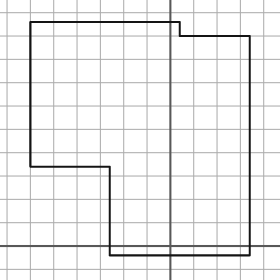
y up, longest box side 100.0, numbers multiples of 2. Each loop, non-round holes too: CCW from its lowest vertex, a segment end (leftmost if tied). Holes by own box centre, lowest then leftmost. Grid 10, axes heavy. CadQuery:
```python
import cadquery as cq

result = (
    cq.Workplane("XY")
    .moveTo(-26.0, -4.0)
    .lineTo(34.0, -4.0)
    .lineTo(34.0, 90.0)
    .lineTo(4.0, 90.0)
    .lineTo(4.0, 96.0)
    .lineTo(-60.0, 96.0)
    .lineTo(-60.0, 34.0)
    .lineTo(-26.0, 34.0)
    .close()
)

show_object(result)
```